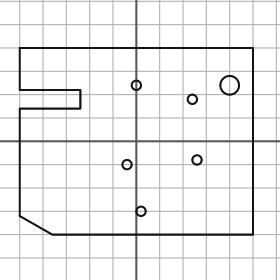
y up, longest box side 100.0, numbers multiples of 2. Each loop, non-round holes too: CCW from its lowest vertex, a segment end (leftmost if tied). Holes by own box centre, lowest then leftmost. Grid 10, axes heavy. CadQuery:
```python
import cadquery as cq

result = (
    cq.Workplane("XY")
    .moveTo(-36.0, -40.0)
    .lineTo(50.0, -40.0)
    .lineTo(50.0, 40.0)
    .lineTo(-50.0, 40.0)
    .lineTo(-50.0, 22.0)
    .lineTo(-24.0, 22.0)
    .lineTo(-24.0, 14.0)
    .lineTo(-50.0, 14.0)
    .lineTo(-50.0, -32.0)
    .close()
    .moveTo(2.0, -30.0)
    .circle(2.0)
    .moveTo(-4.0, -10.0)
    .circle(2.0)
    .moveTo(26.0, -8.0)
    .circle(2.0)
    .moveTo(24.0, 18.0)
    .circle(2.0)
    .moveTo(0.0, 24.0)
    .circle(2.0)
    .moveTo(40.0, 24.0)
    .circle(4.0)
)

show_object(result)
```